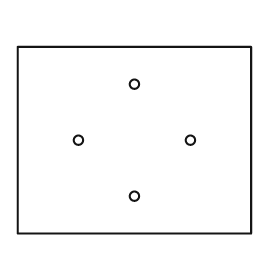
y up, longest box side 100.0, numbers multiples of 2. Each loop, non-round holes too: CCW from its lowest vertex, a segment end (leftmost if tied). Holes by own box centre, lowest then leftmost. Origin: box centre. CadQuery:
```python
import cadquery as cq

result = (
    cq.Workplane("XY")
    .moveTo(-50.0, -40.0)
    .lineTo(50.0, -40.0)
    .lineTo(50.0, 40.0)
    .lineTo(-50.0, 40.0)
    .close()
    .moveTo(0.0, -24.0)
    .circle(2.0)
    .moveTo(-24.0, 0.0)
    .circle(2.0)
    .moveTo(24.0, 0.0)
    .circle(2.0)
    .moveTo(0.0, 24.0)
    .circle(2.0)
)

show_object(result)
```